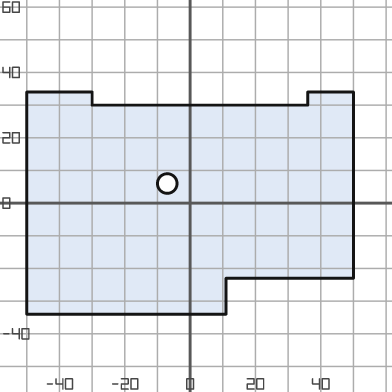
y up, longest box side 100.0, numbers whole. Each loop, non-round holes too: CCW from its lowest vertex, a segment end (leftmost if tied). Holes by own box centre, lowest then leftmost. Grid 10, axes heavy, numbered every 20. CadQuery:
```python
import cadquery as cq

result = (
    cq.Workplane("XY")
    .moveTo(-50.0, -34.0)
    .lineTo(11.0, -34.0)
    .lineTo(11.0, -23.0)
    .lineTo(50.0, -23.0)
    .lineTo(50.0, 34.0)
    .lineTo(36.0, 34.0)
    .lineTo(36.0, 30.0)
    .lineTo(-30.0, 30.0)
    .lineTo(-30.0, 34.0)
    .lineTo(-50.0, 34.0)
    .close()
    .moveTo(-7.0, 6.0)
    .circle(3.0)
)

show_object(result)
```